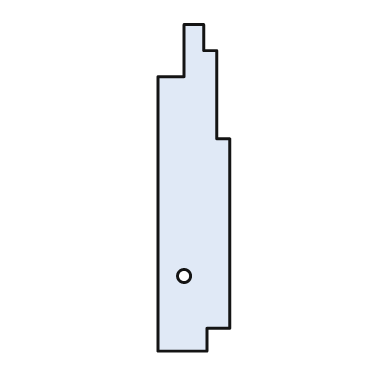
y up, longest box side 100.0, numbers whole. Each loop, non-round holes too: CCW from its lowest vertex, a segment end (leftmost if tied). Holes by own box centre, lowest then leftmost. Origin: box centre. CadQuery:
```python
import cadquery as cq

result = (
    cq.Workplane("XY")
    .moveTo(-11.0, -50.0)
    .lineTo(4.0, -50.0)
    .lineTo(4.0, -43.0)
    .lineTo(11.0, -43.0)
    .lineTo(11.0, 15.0)
    .lineTo(7.0, 15.0)
    .lineTo(7.0, 42.0)
    .lineTo(3.0, 42.0)
    .lineTo(3.0, 50.0)
    .lineTo(-3.0, 50.0)
    .lineTo(-3.0, 34.0)
    .lineTo(-11.0, 34.0)
    .close()
    .moveTo(-3.0, -27.0)
    .circle(2.0)
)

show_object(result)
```